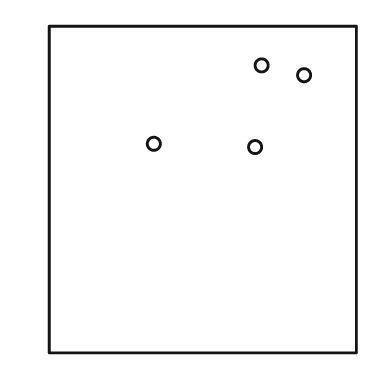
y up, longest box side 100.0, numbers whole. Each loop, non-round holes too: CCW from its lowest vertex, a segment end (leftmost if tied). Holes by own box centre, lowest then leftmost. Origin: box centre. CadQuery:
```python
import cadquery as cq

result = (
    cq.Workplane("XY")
    .moveTo(-47.0, -50.0)
    .lineTo(47.0, -50.0)
    .lineTo(47.0, 50.0)
    .lineTo(-47.0, 50.0)
    .close()
    .moveTo(16.0, 13.0)
    .circle(2.0)
    .moveTo(-15.0, 14.0)
    .circle(2.0)
    .moveTo(31.0, 35.0)
    .circle(2.0)
    .moveTo(18.0, 38.0)
    .circle(2.0)
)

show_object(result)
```